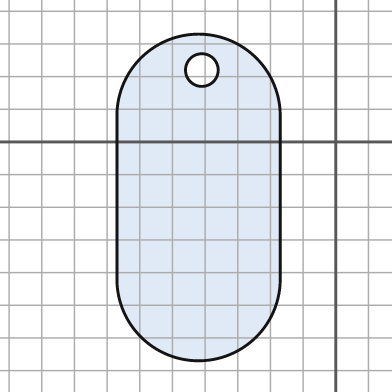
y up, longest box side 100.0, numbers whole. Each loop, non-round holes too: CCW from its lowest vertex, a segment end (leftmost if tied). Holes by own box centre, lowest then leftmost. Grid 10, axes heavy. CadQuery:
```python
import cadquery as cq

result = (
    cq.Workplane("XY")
    .moveTo(-67.0, -42.0)
    .threePointArc((-42.0, -67.0), (-17.0, -42.0))
    .lineTo(-17.0, 8.0)
    .threePointArc((-42.0, 33.0), (-67.0, 8.0))
    .close()
    .moveTo(-41.0, 22.0)
    .circle(5.0)
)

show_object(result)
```